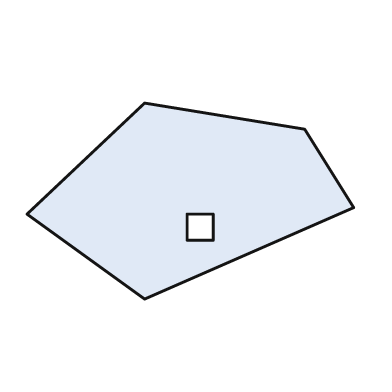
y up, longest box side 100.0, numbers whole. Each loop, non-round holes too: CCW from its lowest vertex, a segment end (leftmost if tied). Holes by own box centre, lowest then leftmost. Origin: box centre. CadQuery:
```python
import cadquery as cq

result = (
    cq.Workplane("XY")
    .moveTo(-14.0, -30.0)
    .lineTo(50.0, -2.0)
    .lineTo(35.0, 22.0)
    .lineTo(-14.0, 30.0)
    .lineTo(-50.0, -4.0)
    .close()
    .moveTo(-1.0, -12.0)
    .lineTo(7.0, -12.0)
    .lineTo(7.0, -4.0)
    .lineTo(-1.0, -4.0)
    .close()
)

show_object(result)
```